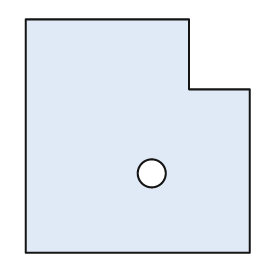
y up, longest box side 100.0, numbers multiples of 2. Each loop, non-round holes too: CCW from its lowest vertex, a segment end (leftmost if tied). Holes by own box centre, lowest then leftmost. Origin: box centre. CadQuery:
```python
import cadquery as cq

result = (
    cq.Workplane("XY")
    .moveTo(-48.0, -50.0)
    .lineTo(48.0, -50.0)
    .lineTo(48.0, 20.0)
    .lineTo(22.0, 20.0)
    .lineTo(22.0, 50.0)
    .lineTo(-48.0, 50.0)
    .close()
    .moveTo(6.0, -16.0)
    .circle(6.0)
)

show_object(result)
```